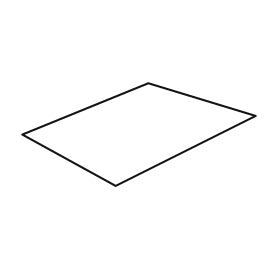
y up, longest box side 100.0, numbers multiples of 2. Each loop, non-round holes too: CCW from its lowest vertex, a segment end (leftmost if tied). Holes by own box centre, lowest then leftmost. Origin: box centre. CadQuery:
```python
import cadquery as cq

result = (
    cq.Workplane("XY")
    .moveTo(-10.0, -22.0)
    .lineTo(50.0, 8.0)
    .lineTo(4.0, 22.0)
    .lineTo(-50.0, 0.0)
    .close()
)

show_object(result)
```